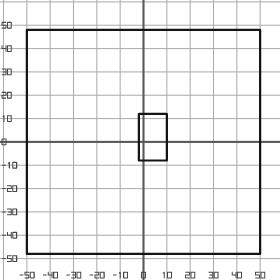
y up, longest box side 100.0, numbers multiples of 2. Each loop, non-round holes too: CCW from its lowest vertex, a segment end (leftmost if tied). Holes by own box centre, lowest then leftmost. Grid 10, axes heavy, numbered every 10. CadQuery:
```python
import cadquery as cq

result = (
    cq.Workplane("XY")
    .moveTo(-50.0, -48.0)
    .lineTo(50.0, -48.0)
    .lineTo(50.0, 48.0)
    .lineTo(-50.0, 48.0)
    .close()
    .moveTo(-2.0, -8.0)
    .lineTo(10.0, -8.0)
    .lineTo(10.0, 12.0)
    .lineTo(-2.0, 12.0)
    .close()
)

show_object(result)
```